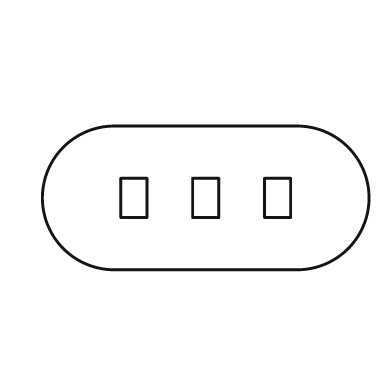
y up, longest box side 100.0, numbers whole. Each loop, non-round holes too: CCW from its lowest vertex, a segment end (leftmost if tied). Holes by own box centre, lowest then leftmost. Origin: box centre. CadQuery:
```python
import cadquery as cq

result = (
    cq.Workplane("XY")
    .moveTo(-28.0, -22.0)
    .lineTo(28.0, -22.0)
    .threePointArc((50.0, 0.0), (28.0, 22.0))
    .lineTo(-28.0, 22.0)
    .threePointArc((-50.0, 0.0), (-28.0, -22.0))
    .close()
    .moveTo(-26.0, -6.0)
    .lineTo(-18.0, -6.0)
    .lineTo(-18.0, 6.0)
    .lineTo(-26.0, 6.0)
    .close()
    .moveTo(-4.0, -6.0)
    .lineTo(4.0, -6.0)
    .lineTo(4.0, 6.0)
    .lineTo(-4.0, 6.0)
    .close()
    .moveTo(18.0, -6.0)
    .lineTo(26.0, -6.0)
    .lineTo(26.0, 6.0)
    .lineTo(18.0, 6.0)
    .close()
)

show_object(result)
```